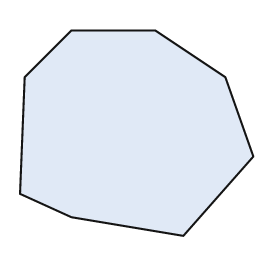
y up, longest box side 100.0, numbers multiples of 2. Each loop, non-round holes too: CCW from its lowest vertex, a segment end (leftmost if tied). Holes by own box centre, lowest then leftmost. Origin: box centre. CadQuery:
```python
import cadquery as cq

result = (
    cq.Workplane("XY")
    .moveTo(20.0, -44.0)
    .lineTo(50.0, -10.0)
    .lineTo(38.0, 24.0)
    .lineTo(8.0, 44.0)
    .lineTo(-28.0, 44.0)
    .lineTo(-48.0, 24.0)
    .lineTo(-50.0, -26.0)
    .lineTo(-28.0, -36.0)
    .close()
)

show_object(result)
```